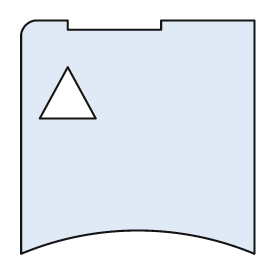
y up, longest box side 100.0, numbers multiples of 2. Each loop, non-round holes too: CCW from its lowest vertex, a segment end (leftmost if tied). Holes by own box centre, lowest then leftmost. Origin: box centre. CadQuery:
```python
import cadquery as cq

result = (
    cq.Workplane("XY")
    .moveTo(-50.0, -50.0)
    .threePointArc((0.0, -40.0), (50.0, -50.0))
    .lineTo(50.0, 50.0)
    .lineTo(10.0, 50.0)
    .lineTo(10.0, 46.0)
    .lineTo(-30.0, 46.0)
    .lineTo(-30.0, 50.0)
    .lineTo(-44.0, 50.0)
    .threePointArc((-48.0, 48.0), (-50.0, 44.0))
    .close()
    .moveTo(-42.0, 8.0)
    .lineTo(-18.0, 8.0)
    .lineTo(-30.0, 30.0)
    .close()
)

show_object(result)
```